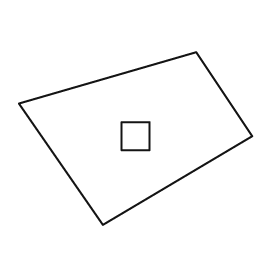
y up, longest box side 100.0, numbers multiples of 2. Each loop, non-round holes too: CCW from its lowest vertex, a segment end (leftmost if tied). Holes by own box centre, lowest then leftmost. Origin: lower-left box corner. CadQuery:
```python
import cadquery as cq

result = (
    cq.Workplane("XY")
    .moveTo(36.0, 0.0)
    .lineTo(100.0, 38.0)
    .lineTo(76.0, 74.0)
    .lineTo(0.0, 52.0)
    .close()
    .moveTo(44.0, 32.0)
    .lineTo(56.0, 32.0)
    .lineTo(56.0, 44.0)
    .lineTo(44.0, 44.0)
    .close()
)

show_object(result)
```